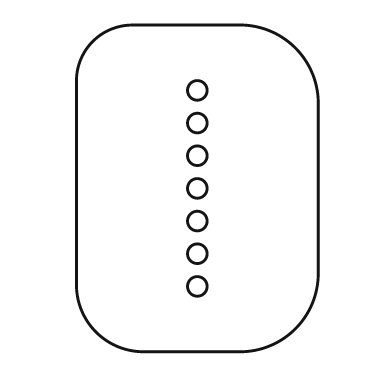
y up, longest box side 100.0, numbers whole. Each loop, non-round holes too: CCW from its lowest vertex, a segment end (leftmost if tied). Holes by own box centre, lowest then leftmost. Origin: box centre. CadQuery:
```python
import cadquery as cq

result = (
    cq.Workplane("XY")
    .moveTo(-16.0, -50.0)
    .lineTo(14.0, -50.0)
    .threePointArc((30.0, -43.0), (37.0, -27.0))
    .lineTo(37.0, 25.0)
    .threePointArc((30.0, 43.0), (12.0, 50.0))
    .lineTo(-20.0, 50.0)
    .threePointArc((-32.0, 45.0), (-37.0, 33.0))
    .lineTo(-37.0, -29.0)
    .threePointArc((-31.0, -44.0), (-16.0, -50.0))
    .close()
    .moveTo(0.0, -30.0)
    .circle(3.0)
    .moveTo(0.0, -20.0)
    .circle(3.0)
    .moveTo(0.0, -10.0)
    .circle(3.0)
    .moveTo(0.0, 0.0)
    .circle(3.0)
    .moveTo(0.0, 10.0)
    .circle(3.0)
    .moveTo(0.0, 20.0)
    .circle(3.0)
    .moveTo(0.0, 30.0)
    .circle(3.0)
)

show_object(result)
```